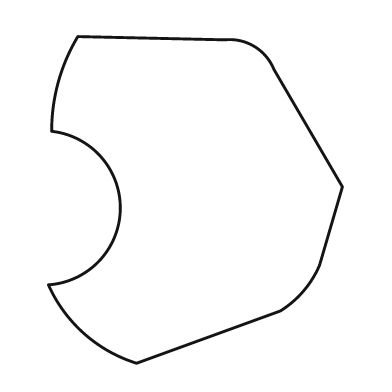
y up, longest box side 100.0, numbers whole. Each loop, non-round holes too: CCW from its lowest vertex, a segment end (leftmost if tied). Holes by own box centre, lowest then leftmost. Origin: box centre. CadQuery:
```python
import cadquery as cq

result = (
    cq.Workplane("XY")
    .moveTo(-18.0, -50.0)
    .lineTo(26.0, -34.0)
    .threePointArc((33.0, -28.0), (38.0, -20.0))
    .lineTo(45.0, 4.0)
    .lineTo(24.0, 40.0)
    .threePointArc((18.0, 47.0), (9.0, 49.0))
    .lineTo(-36.0, 50.0)
    .threePointArc((-42.0, 36.0), (-44.0, 21.0))
    .threePointArc((-23.0, -3.0), (-45.0, -26.0))
    .threePointArc((-34.0, -41.0), (-18.0, -50.0))
    .close()
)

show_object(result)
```